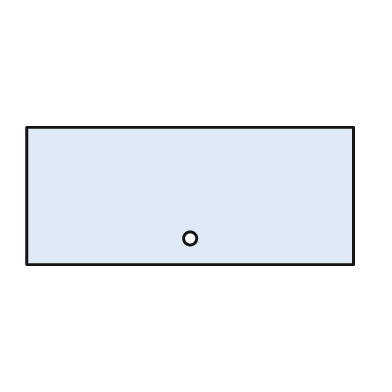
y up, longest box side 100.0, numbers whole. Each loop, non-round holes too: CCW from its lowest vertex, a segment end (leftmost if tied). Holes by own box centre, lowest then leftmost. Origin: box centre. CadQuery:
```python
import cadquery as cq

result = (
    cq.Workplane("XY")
    .moveTo(-50.0, -21.0)
    .lineTo(50.0, -21.0)
    .lineTo(50.0, 21.0)
    .lineTo(-50.0, 21.0)
    .close()
    .moveTo(0.0, -13.0)
    .circle(2.0)
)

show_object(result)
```